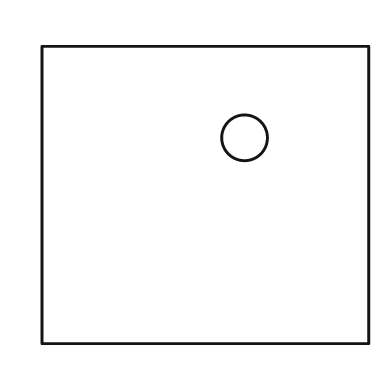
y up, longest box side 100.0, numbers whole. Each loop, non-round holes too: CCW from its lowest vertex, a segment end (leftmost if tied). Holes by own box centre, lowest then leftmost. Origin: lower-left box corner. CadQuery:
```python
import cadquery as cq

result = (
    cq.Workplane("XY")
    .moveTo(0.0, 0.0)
    .lineTo(100.0, 0.0)
    .lineTo(100.0, 91.0)
    .lineTo(0.0, 91.0)
    .close()
    .moveTo(62.0, 63.0)
    .circle(7.0)
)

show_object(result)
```